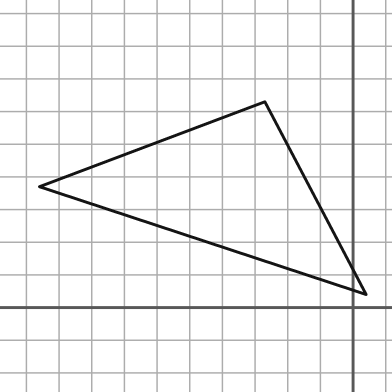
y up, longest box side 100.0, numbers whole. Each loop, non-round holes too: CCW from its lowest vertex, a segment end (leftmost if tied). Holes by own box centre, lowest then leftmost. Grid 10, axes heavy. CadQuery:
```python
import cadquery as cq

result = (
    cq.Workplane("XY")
    .moveTo(4.0, 4.0)
    .lineTo(-27.0, 63.0)
    .lineTo(-96.0, 37.0)
    .close()
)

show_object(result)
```